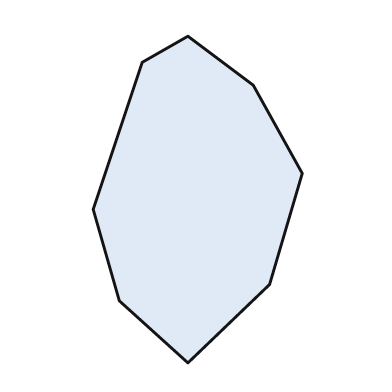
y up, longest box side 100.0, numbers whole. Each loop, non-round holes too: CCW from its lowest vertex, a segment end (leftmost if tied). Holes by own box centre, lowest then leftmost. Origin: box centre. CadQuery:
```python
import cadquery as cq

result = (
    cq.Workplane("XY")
    .moveTo(-3.0, -50.0)
    .lineTo(22.0, -26.0)
    .lineTo(32.0, 8.0)
    .lineTo(17.0, 35.0)
    .lineTo(-3.0, 50.0)
    .lineTo(-17.0, 42.0)
    .lineTo(-32.0, -3.0)
    .lineTo(-24.0, -31.0)
    .close()
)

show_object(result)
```